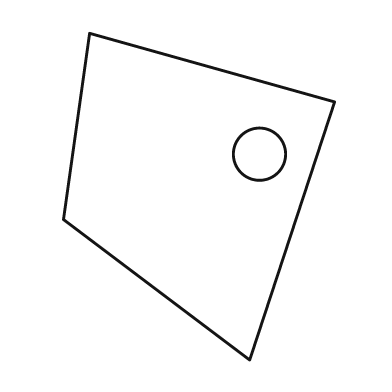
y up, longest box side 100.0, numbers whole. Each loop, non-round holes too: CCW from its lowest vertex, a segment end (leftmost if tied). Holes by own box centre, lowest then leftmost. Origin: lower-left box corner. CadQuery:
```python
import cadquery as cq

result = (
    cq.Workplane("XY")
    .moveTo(57.0, 0.0)
    .lineTo(83.0, 79.0)
    .lineTo(8.0, 100.0)
    .lineTo(0.0, 43.0)
    .close()
    .moveTo(60.0, 63.0)
    .circle(8.0)
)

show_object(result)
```